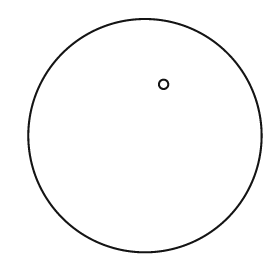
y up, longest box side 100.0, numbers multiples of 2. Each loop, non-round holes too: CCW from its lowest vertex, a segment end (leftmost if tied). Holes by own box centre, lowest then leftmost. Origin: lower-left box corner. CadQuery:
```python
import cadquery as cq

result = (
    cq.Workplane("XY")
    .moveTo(50.0, 50.0)
    .circle(50.0)
    .moveTo(58.0, 72.0)
    .circle(2.0)
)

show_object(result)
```